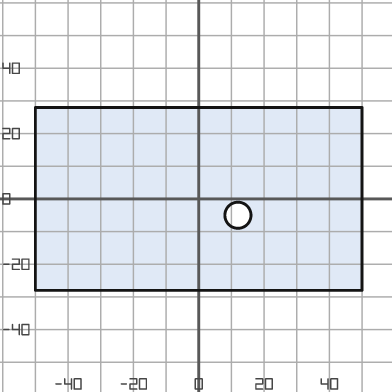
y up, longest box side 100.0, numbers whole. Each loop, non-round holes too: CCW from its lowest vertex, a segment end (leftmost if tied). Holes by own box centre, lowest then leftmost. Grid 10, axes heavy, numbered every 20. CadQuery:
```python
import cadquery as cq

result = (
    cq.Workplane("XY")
    .moveTo(-50.0, -28.0)
    .lineTo(50.0, -28.0)
    .lineTo(50.0, 28.0)
    .lineTo(-50.0, 28.0)
    .close()
    .moveTo(12.0, -5.0)
    .circle(4.0)
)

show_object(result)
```